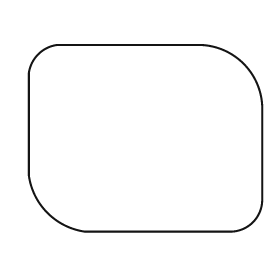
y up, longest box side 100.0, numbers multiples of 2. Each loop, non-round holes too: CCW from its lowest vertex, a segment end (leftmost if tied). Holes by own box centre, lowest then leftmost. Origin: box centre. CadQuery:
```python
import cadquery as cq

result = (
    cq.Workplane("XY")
    .moveTo(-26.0, -40.0)
    .lineTo(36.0, -40.0)
    .threePointArc((46.0, -36.0), (50.0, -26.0))
    .lineTo(50.0, 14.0)
    .threePointArc((42.0, 32.0), (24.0, 40.0))
    .lineTo(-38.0, 40.0)
    .threePointArc((-46.0, 36.0), (-50.0, 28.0))
    .lineTo(-50.0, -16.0)
    .threePointArc((-42.0, -32.0), (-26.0, -40.0))
    .close()
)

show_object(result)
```